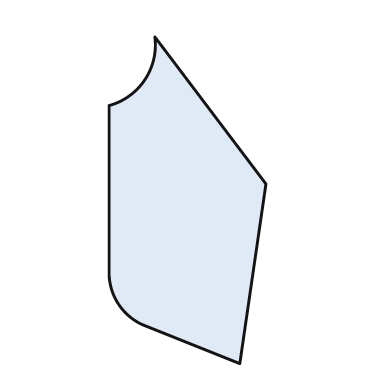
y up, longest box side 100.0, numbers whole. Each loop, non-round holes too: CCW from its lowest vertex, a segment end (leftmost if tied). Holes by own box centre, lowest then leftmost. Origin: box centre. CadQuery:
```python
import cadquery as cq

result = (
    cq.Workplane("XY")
    .moveTo(16.0, -50.0)
    .lineTo(24.0, 5.0)
    .lineTo(-10.0, 50.0)
    .threePointArc((-13.0, 37.0), (-24.0, 29.0))
    .lineTo(-24.0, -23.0)
    .threePointArc((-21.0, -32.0), (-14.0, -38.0))
    .close()
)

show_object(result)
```